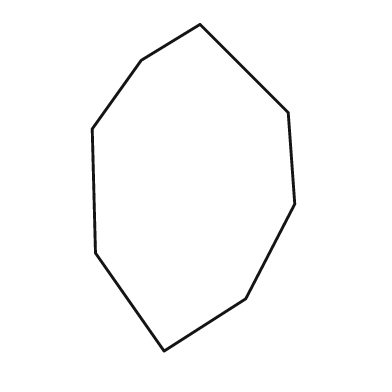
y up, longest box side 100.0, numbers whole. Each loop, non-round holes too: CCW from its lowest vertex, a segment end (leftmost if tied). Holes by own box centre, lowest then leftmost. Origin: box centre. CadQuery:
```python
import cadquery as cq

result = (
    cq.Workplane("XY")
    .moveTo(-9.0, -50.0)
    .lineTo(16.0, -34.0)
    .lineTo(31.0, -5.0)
    .lineTo(29.0, 23.0)
    .lineTo(2.0, 50.0)
    .lineTo(-16.0, 39.0)
    .lineTo(-31.0, 18.0)
    .lineTo(-30.0, -20.0)
    .close()
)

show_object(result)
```